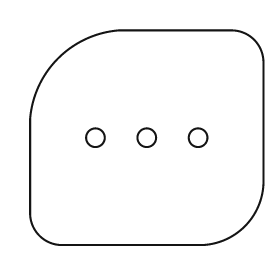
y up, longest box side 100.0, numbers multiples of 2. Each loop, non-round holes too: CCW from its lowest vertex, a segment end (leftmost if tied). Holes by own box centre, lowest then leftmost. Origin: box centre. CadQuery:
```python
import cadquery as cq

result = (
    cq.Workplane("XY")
    .moveTo(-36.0, -46.0)
    .lineTo(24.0, -46.0)
    .threePointArc((42.0, -38.0), (50.0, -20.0))
    .lineTo(50.0, 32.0)
    .threePointArc((46.0, 42.0), (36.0, 46.0))
    .lineTo(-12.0, 46.0)
    .threePointArc((-38.0, 34.0), (-50.0, 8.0))
    .lineTo(-50.0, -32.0)
    .threePointArc((-46.0, -42.0), (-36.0, -46.0))
    .close()
    .moveTo(-22.0, 0.0)
    .circle(4.0)
    .moveTo(0.0, 0.0)
    .circle(4.0)
    .moveTo(22.0, 0.0)
    .circle(4.0)
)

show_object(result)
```